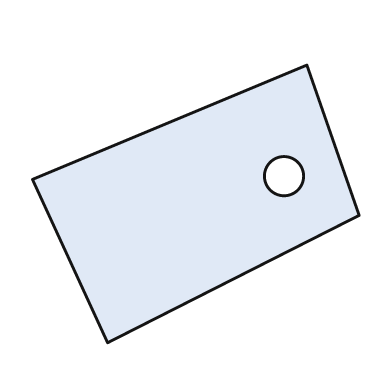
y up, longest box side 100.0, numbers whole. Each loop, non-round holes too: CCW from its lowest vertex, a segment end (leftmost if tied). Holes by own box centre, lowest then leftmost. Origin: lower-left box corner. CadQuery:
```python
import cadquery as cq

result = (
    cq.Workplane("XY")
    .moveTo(23.0, 0.0)
    .lineTo(100.0, 39.0)
    .lineTo(84.0, 85.0)
    .lineTo(0.0, 50.0)
    .close()
    .moveTo(77.0, 51.0)
    .circle(6.0)
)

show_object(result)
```